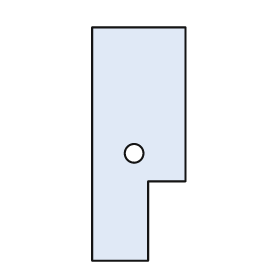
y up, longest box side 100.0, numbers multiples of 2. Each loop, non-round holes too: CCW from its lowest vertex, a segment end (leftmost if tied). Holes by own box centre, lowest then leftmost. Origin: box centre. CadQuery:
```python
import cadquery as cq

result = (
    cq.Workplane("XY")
    .moveTo(-20.0, -50.0)
    .lineTo(4.0, -50.0)
    .lineTo(4.0, -16.0)
    .lineTo(20.0, -16.0)
    .lineTo(20.0, 50.0)
    .lineTo(-20.0, 50.0)
    .close()
    .moveTo(-2.0, -4.0)
    .circle(4.0)
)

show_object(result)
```